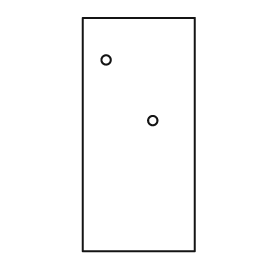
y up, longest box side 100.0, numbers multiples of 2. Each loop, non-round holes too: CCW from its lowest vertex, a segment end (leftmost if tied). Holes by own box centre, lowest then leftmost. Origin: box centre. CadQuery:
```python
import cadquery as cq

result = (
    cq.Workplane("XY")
    .moveTo(-24.0, -50.0)
    .lineTo(24.0, -50.0)
    .lineTo(24.0, 50.0)
    .lineTo(-24.0, 50.0)
    .close()
    .moveTo(6.0, 6.0)
    .circle(2.0)
    .moveTo(-14.0, 32.0)
    .circle(2.0)
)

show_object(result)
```